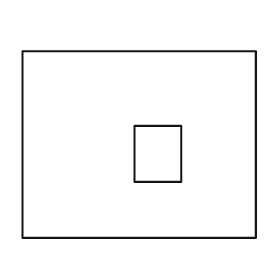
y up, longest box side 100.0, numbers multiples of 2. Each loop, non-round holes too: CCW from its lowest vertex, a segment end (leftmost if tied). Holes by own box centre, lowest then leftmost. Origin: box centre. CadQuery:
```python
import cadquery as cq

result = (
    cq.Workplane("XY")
    .moveTo(-50.0, -40.0)
    .lineTo(50.0, -40.0)
    .lineTo(50.0, 40.0)
    .lineTo(-50.0, 40.0)
    .close()
    .moveTo(-2.0, -16.0)
    .lineTo(18.0, -16.0)
    .lineTo(18.0, 8.0)
    .lineTo(-2.0, 8.0)
    .close()
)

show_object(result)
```